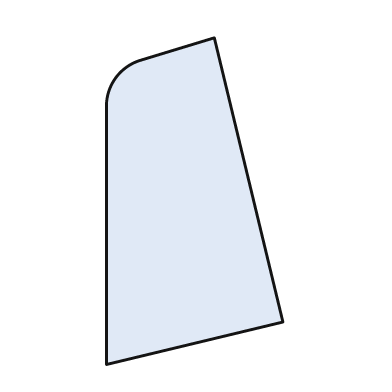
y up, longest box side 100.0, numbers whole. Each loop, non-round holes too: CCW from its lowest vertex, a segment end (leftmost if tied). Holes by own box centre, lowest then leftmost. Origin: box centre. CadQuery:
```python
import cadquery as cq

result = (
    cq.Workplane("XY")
    .moveTo(-27.0, -50.0)
    .lineTo(27.0, -37.0)
    .lineTo(6.0, 50.0)
    .lineTo(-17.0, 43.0)
    .threePointArc((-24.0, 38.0), (-27.0, 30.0))
    .close()
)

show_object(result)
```